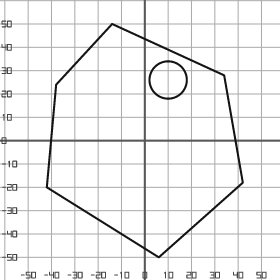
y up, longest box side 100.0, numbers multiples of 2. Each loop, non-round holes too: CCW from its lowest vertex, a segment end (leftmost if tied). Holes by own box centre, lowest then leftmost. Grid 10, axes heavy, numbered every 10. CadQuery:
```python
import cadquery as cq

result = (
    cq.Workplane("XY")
    .moveTo(6.0, -50.0)
    .lineTo(42.0, -18.0)
    .lineTo(34.0, 28.0)
    .lineTo(-14.0, 50.0)
    .lineTo(-38.0, 24.0)
    .lineTo(-42.0, -20.0)
    .close()
    .moveTo(10.0, 26.0)
    .circle(8.0)
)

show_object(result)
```